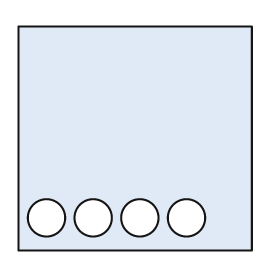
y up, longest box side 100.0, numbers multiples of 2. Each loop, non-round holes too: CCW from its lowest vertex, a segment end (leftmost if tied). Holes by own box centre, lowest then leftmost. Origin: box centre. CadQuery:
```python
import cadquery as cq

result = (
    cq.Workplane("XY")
    .moveTo(-50.0, -48.0)
    .lineTo(50.0, -48.0)
    .lineTo(50.0, 48.0)
    .lineTo(-50.0, 48.0)
    .close()
    .moveTo(-38.0, -34.0)
    .circle(8.0)
    .moveTo(-18.0, -34.0)
    .circle(8.0)
    .moveTo(2.0, -34.0)
    .circle(8.0)
    .moveTo(22.0, -34.0)
    .circle(8.0)
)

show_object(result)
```